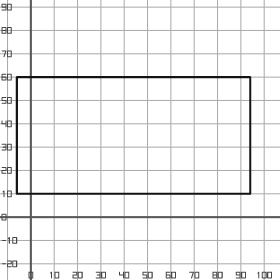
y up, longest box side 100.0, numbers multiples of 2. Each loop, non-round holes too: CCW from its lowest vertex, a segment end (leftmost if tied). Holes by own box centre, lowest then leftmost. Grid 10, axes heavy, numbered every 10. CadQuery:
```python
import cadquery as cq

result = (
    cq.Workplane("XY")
    .moveTo(-6.0, 10.0)
    .lineTo(94.0, 10.0)
    .lineTo(94.0, 60.0)
    .lineTo(-6.0, 60.0)
    .close()
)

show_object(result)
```